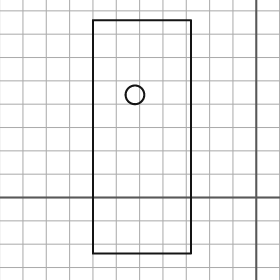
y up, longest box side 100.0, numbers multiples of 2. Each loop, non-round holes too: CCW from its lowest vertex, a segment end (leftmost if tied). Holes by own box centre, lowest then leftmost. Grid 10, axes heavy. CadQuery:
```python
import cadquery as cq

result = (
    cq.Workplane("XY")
    .moveTo(-70.0, -24.0)
    .lineTo(-28.0, -24.0)
    .lineTo(-28.0, 76.0)
    .lineTo(-70.0, 76.0)
    .close()
    .moveTo(-52.0, 44.0)
    .circle(4.0)
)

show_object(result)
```